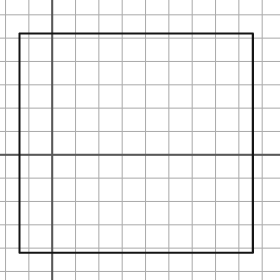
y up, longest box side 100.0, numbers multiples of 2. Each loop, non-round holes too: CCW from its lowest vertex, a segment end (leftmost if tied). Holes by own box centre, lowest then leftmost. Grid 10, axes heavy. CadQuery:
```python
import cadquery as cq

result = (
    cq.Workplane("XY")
    .moveTo(-14.0, -42.0)
    .lineTo(86.0, -42.0)
    .lineTo(86.0, 52.0)
    .lineTo(-14.0, 52.0)
    .close()
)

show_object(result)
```